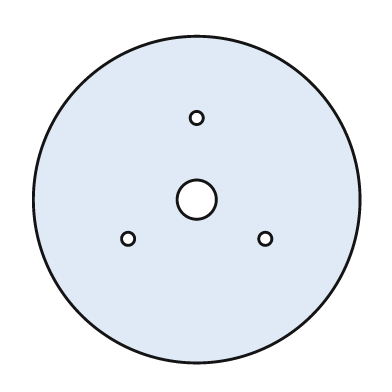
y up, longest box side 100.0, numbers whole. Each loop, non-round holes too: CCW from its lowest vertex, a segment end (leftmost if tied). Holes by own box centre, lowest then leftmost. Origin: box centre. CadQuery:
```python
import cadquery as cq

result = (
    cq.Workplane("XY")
    .moveTo(0.0, 0.0)
    .circle(50.0)
    .moveTo(-21.0, -12.0)
    .circle(2.0)
    .moveTo(21.0, -12.0)
    .circle(2.0)
    .moveTo(0.0, 0.0)
    .circle(6.0)
    .moveTo(0.0, 25.0)
    .circle(2.0)
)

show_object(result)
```